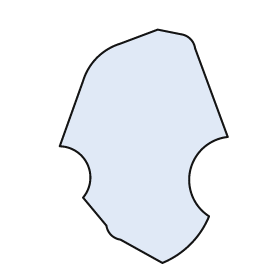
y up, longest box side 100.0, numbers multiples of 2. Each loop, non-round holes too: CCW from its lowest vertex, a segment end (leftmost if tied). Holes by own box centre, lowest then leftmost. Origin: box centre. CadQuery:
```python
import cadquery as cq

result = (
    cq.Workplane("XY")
    .moveTo(8.0, -50.0)
    .threePointArc((20.0, -42.0), (28.0, -30.0))
    .threePointArc((20.0, -10.0), (36.0, 4.0))
    .lineTo(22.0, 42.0)
    .threePointArc((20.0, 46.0), (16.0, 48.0))
    .lineTo(6.0, 50.0)
    .lineTo(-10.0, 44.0)
    .threePointArc((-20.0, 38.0), (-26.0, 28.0))
    .lineTo(-36.0, 0.0)
    .threePointArc((-24.0, -8.0), (-26.0, -22.0))
    .lineTo(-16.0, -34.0)
    .threePointArc((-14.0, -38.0), (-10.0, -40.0))
    .close()
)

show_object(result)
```